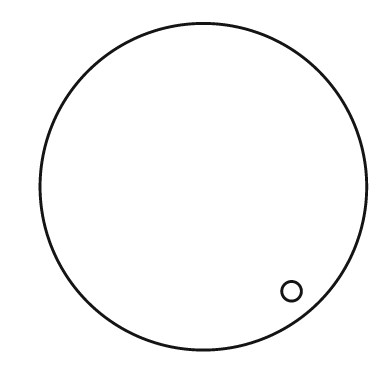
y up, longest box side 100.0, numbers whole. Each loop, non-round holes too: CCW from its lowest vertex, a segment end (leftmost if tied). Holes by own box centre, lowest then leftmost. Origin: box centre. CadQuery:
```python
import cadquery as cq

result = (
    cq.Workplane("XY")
    .moveTo(0.0, 0.0)
    .circle(50.0)
    .moveTo(27.0, -32.0)
    .circle(3.0)
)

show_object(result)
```